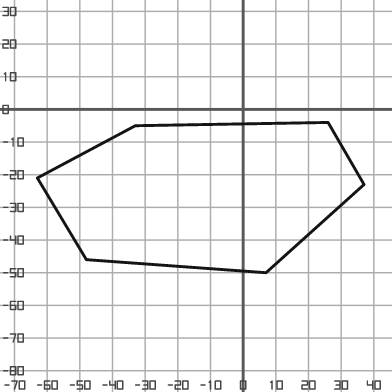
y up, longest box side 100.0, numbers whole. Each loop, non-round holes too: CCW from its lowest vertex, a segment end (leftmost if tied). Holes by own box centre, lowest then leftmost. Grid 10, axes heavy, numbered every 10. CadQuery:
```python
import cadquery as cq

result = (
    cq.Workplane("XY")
    .moveTo(7.0, -50.0)
    .lineTo(37.0, -23.0)
    .lineTo(26.0, -4.0)
    .lineTo(-33.0, -5.0)
    .lineTo(-63.0, -21.0)
    .lineTo(-48.0, -46.0)
    .close()
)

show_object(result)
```